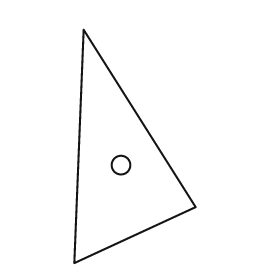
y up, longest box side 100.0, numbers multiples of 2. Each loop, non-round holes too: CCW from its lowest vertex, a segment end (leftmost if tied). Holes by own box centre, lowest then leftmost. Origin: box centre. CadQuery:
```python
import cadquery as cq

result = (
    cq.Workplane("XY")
    .moveTo(-26.0, -50.0)
    .lineTo(26.0, -26.0)
    .lineTo(-22.0, 50.0)
    .close()
    .moveTo(-6.0, -8.0)
    .circle(4.0)
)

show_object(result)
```